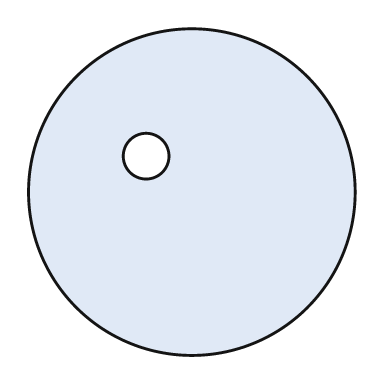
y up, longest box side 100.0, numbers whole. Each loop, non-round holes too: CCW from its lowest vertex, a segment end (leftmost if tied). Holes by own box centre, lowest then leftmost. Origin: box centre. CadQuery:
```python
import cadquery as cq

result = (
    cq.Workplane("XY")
    .moveTo(0.0, 0.0)
    .circle(50.0)
    .moveTo(-14.0, 11.0)
    .circle(7.0)
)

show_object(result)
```